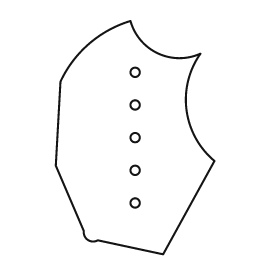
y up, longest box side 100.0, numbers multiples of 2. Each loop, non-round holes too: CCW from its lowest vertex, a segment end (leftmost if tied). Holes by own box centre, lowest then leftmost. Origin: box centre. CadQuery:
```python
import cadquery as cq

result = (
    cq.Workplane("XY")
    .moveTo(12.0, -50.0)
    .lineTo(34.0, -10.0)
    .threePointArc((22.0, 12.0), (28.0, 36.0))
    .threePointArc((10.0, 36.0), (-2.0, 50.0))
    .threePointArc((-20.0, 40.0), (-32.0, 24.0))
    .lineTo(-34.0, -12.0)
    .lineTo(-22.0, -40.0)
    .threePointArc((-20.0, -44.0), (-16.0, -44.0))
    .close()
    .moveTo(0.0, -28.0)
    .circle(2.0)
    .moveTo(0.0, -14.0)
    .circle(2.0)
    .moveTo(0.0, 0.0)
    .circle(2.0)
    .moveTo(0.0, 14.0)
    .circle(2.0)
    .moveTo(0.0, 28.0)
    .circle(2.0)
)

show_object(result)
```